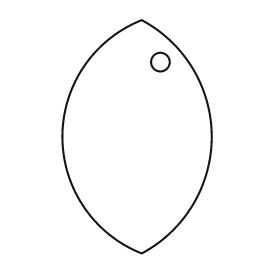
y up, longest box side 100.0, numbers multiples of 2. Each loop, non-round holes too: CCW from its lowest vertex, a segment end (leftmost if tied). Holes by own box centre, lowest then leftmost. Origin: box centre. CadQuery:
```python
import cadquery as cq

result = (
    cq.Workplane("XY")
    .moveTo(2.0, -50.0)
    .threePointArc((32.0, 0.0), (2.0, 50.0))
    .threePointArc((-32.0, 0.0), (2.0, -50.0))
    .close()
    .moveTo(10.0, 32.0)
    .circle(4.0)
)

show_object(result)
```